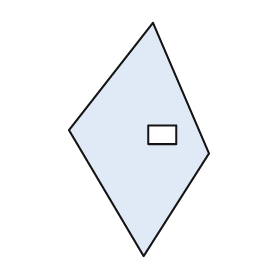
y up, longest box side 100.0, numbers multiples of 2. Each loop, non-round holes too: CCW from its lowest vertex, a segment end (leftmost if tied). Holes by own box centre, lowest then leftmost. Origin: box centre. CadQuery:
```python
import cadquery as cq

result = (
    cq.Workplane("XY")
    .moveTo(2.0, -50.0)
    .lineTo(30.0, -6.0)
    .lineTo(6.0, 50.0)
    .lineTo(-30.0, 4.0)
    .close()
    .moveTo(4.0, -2.0)
    .lineTo(16.0, -2.0)
    .lineTo(16.0, 6.0)
    .lineTo(4.0, 6.0)
    .close()
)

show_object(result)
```